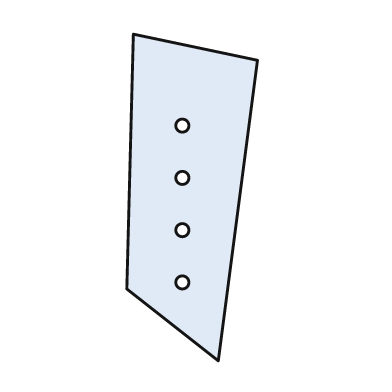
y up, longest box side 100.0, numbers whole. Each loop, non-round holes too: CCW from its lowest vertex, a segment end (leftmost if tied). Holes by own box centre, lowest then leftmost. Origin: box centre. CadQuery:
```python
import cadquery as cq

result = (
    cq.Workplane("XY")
    .moveTo(8.0, -50.0)
    .lineTo(20.0, 42.0)
    .lineTo(-18.0, 50.0)
    .lineTo(-20.0, -28.0)
    .close()
    .moveTo(-3.0, -26.0)
    .circle(2.0)
    .moveTo(-3.0, -10.0)
    .circle(2.0)
    .moveTo(-3.0, 6.0)
    .circle(2.0)
    .moveTo(-3.0, 22.0)
    .circle(2.0)
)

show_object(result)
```